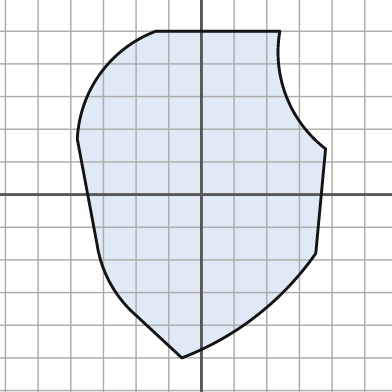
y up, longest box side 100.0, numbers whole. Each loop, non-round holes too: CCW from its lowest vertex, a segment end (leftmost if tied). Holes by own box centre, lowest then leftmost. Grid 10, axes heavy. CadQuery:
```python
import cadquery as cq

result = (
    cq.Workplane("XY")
    .moveTo(-6.0, -50.0)
    .threePointArc((17.0, -37.0), (35.0, -18.0))
    .lineTo(38.0, 14.0)
    .threePointArc((26.0, 30.0), (24.0, 50.0))
    .lineTo(-14.0, 50.0)
    .threePointArc((-31.0, 37.0), (-38.0, 17.0))
    .lineTo(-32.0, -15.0)
    .threePointArc((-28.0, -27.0), (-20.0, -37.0))
    .close()
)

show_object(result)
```